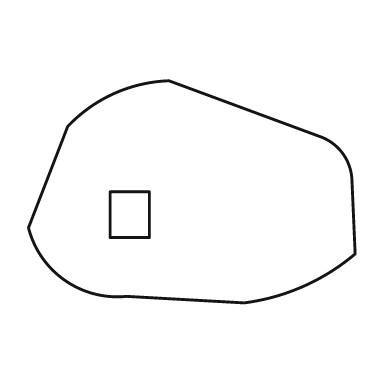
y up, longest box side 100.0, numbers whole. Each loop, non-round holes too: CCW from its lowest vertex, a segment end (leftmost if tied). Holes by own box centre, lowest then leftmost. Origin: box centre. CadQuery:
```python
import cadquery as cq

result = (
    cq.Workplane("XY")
    .moveTo(16.0, -34.0)
    .threePointArc((34.0, -29.0), (50.0, -19.0))
    .lineTo(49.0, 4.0)
    .threePointArc((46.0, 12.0), (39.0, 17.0))
    .lineTo(-7.0, 34.0)
    .threePointArc((-24.0, 30.0), (-38.0, 20.0))
    .lineTo(-50.0, -11.0)
    .threePointArc((-39.0, -27.0), (-20.0, -32.0))
    .close()
    .moveTo(-25.0, -14.0)
    .lineTo(-13.0, -14.0)
    .lineTo(-13.0, 0.0)
    .lineTo(-25.0, 0.0)
    .close()
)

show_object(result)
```